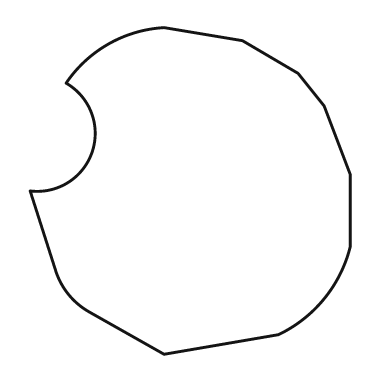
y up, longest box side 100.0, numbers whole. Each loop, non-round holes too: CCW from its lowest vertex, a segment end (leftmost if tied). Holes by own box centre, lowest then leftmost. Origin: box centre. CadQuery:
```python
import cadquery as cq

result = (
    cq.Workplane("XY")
    .moveTo(-8.0, -50.0)
    .lineTo(27.0, -44.0)
    .threePointArc((41.0, -33.0), (49.0, -17.0))
    .lineTo(49.0, 5.0)
    .lineTo(41.0, 26.0)
    .lineTo(33.0, 36.0)
    .lineTo(16.0, 46.0)
    .lineTo(-8.0, 50.0)
    .threePointArc((-25.0, 45.0), (-38.0, 33.0))
    .threePointArc((-30.0, 12.0), (-49.0, 0.0))
    .lineTo(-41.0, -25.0)
    .threePointArc((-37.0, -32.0), (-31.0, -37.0))
    .close()
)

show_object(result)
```